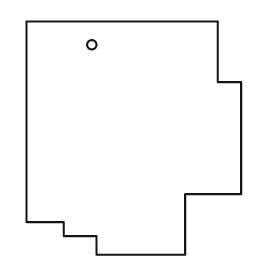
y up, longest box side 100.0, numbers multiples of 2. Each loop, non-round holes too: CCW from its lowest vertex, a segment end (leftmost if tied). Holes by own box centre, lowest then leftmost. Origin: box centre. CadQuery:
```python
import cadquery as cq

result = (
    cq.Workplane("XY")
    .moveTo(-16.0, -50.0)
    .lineTo(22.0, -50.0)
    .lineTo(22.0, -24.0)
    .lineTo(46.0, -24.0)
    .lineTo(46.0, 24.0)
    .lineTo(36.0, 24.0)
    .lineTo(36.0, 50.0)
    .lineTo(-46.0, 50.0)
    .lineTo(-46.0, -36.0)
    .lineTo(-30.0, -36.0)
    .lineTo(-30.0, -42.0)
    .lineTo(-16.0, -42.0)
    .close()
    .moveTo(-18.0, 40.0)
    .circle(2.0)
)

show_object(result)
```